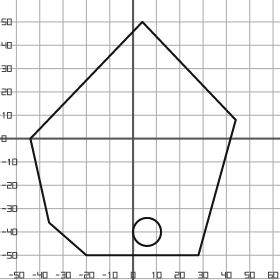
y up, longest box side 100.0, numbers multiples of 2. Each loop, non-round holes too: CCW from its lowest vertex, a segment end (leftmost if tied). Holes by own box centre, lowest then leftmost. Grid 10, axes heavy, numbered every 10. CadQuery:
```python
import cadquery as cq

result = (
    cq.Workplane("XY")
    .moveTo(-20.0, -50.0)
    .lineTo(28.0, -50.0)
    .lineTo(44.0, 8.0)
    .lineTo(4.0, 50.0)
    .lineTo(-44.0, 0.0)
    .lineTo(-36.0, -36.0)
    .close()
    .moveTo(6.0, -40.0)
    .circle(6.0)
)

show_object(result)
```